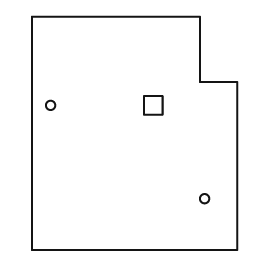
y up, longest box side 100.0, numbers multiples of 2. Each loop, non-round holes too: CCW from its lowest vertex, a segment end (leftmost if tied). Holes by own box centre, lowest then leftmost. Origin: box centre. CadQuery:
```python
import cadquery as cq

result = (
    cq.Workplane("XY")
    .moveTo(-44.0, -50.0)
    .lineTo(44.0, -50.0)
    .lineTo(44.0, 22.0)
    .lineTo(28.0, 22.0)
    .lineTo(28.0, 50.0)
    .lineTo(-44.0, 50.0)
    .close()
    .moveTo(30.0, -28.0)
    .circle(2.0)
    .moveTo(-36.0, 12.0)
    .circle(2.0)
    .moveTo(4.0, 8.0)
    .lineTo(12.0, 8.0)
    .lineTo(12.0, 16.0)
    .lineTo(4.0, 16.0)
    .close()
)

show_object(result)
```